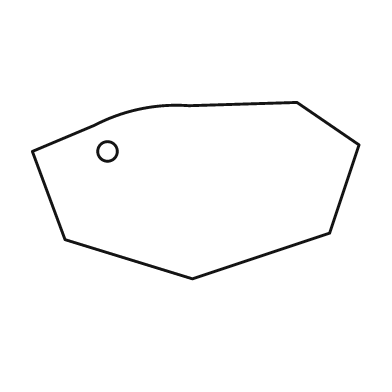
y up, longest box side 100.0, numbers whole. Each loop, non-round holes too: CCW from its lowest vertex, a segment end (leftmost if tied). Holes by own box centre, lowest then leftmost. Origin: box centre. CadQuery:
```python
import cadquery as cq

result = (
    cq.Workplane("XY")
    .moveTo(-1.0, -27.0)
    .lineTo(41.0, -13.0)
    .lineTo(50.0, 14.0)
    .lineTo(31.0, 27.0)
    .lineTo(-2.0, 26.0)
    .threePointArc((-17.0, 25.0), (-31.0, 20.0))
    .lineTo(-50.0, 12.0)
    .lineTo(-40.0, -15.0)
    .close()
    .moveTo(-27.0, 12.0)
    .circle(3.0)
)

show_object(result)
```